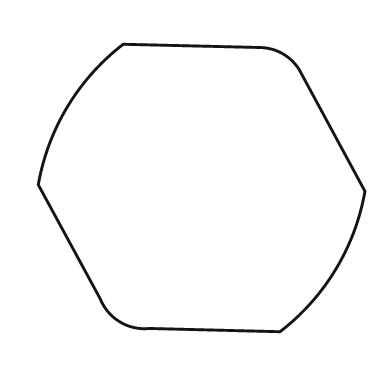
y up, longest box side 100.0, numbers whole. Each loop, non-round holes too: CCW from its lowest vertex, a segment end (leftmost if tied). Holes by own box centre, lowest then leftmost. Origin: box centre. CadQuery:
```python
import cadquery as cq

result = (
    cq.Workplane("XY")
    .moveTo(24.0, -44.0)
    .threePointArc((41.0, -25.0), (50.0, -1.0))
    .lineTo(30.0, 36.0)
    .threePointArc((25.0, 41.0), (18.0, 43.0))
    .lineTo(-24.0, 44.0)
    .threePointArc((-41.0, 25.0), (-50.0, 1.0))
    .lineTo(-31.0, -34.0)
    .threePointArc((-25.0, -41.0), (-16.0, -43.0))
    .close()
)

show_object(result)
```